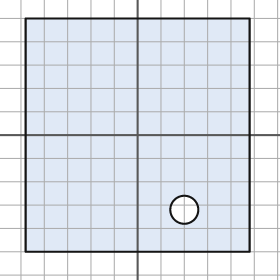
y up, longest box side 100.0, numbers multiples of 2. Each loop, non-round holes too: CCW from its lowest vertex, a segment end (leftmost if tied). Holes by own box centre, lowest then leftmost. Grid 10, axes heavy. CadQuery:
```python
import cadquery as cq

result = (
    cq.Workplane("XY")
    .moveTo(-48.0, -50.0)
    .lineTo(48.0, -50.0)
    .lineTo(48.0, 50.0)
    .lineTo(-48.0, 50.0)
    .close()
    .moveTo(20.0, -32.0)
    .circle(6.0)
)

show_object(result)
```